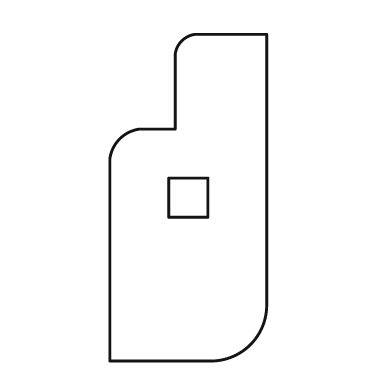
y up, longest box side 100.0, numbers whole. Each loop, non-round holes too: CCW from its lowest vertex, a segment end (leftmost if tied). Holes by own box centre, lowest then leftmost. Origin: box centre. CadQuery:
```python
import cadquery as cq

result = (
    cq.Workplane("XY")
    .moveTo(-24.0, -50.0)
    .lineTo(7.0, -50.0)
    .threePointArc((19.0, -45.0), (24.0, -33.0))
    .lineTo(24.0, 50.0)
    .lineTo(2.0, 50.0)
    .threePointArc((-2.0, 48.0), (-4.0, 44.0))
    .lineTo(-4.0, 21.0)
    .lineTo(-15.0, 21.0)
    .threePointArc((-21.0, 18.0), (-24.0, 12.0))
    .close()
    .moveTo(-6.0, -6.0)
    .lineTo(6.0, -6.0)
    .lineTo(6.0, 6.0)
    .lineTo(-6.0, 6.0)
    .close()
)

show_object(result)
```